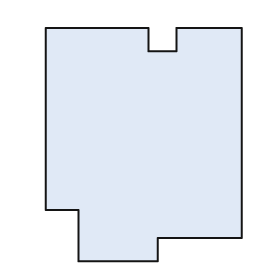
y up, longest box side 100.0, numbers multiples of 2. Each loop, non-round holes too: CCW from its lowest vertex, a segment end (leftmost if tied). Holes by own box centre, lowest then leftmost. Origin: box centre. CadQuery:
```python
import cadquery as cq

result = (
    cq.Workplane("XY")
    .moveTo(-28.0, -50.0)
    .lineTo(6.0, -50.0)
    .lineTo(6.0, -40.0)
    .lineTo(42.0, -40.0)
    .lineTo(42.0, 50.0)
    .lineTo(14.0, 50.0)
    .lineTo(14.0, 40.0)
    .lineTo(2.0, 40.0)
    .lineTo(2.0, 50.0)
    .lineTo(-42.0, 50.0)
    .lineTo(-42.0, -28.0)
    .lineTo(-28.0, -28.0)
    .close()
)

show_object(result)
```